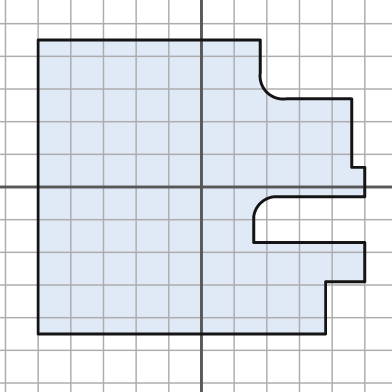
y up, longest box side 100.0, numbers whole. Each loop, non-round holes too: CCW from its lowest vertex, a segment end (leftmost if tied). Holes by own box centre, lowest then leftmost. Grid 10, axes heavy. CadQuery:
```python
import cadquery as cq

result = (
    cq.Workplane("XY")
    .moveTo(-50.0, -45.0)
    .lineTo(38.0, -45.0)
    .lineTo(38.0, -29.0)
    .lineTo(50.0, -29.0)
    .lineTo(50.0, -17.0)
    .lineTo(16.0, -17.0)
    .lineTo(16.0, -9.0)
    .threePointArc((18.0, -5.0), (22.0, -3.0))
    .lineTo(50.0, -3.0)
    .lineTo(50.0, 6.0)
    .lineTo(46.0, 6.0)
    .lineTo(46.0, 27.0)
    .lineTo(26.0, 27.0)
    .threePointArc((20.0, 29.0), (18.0, 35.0))
    .lineTo(18.0, 45.0)
    .lineTo(-50.0, 45.0)
    .close()
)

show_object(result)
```